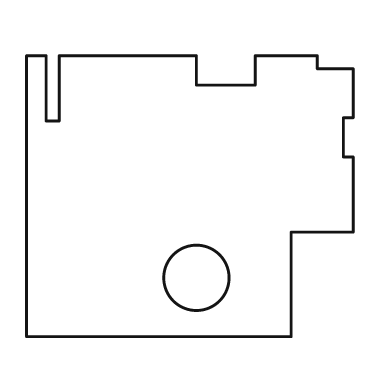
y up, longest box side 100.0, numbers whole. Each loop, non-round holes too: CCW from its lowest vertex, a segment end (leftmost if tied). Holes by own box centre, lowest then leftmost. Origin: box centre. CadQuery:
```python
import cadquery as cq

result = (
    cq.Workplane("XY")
    .moveTo(-50.0, -43.0)
    .lineTo(31.0, -43.0)
    .lineTo(31.0, -11.0)
    .lineTo(50.0, -11.0)
    .lineTo(50.0, 12.0)
    .lineTo(47.0, 12.0)
    .lineTo(47.0, 24.0)
    .lineTo(50.0, 24.0)
    .lineTo(50.0, 39.0)
    .lineTo(39.0, 39.0)
    .lineTo(39.0, 43.0)
    .lineTo(20.0, 43.0)
    .lineTo(20.0, 34.0)
    .lineTo(2.0, 34.0)
    .lineTo(2.0, 43.0)
    .lineTo(-40.0, 43.0)
    .lineTo(-40.0, 23.0)
    .lineTo(-44.0, 23.0)
    .lineTo(-44.0, 43.0)
    .lineTo(-50.0, 43.0)
    .close()
    .moveTo(2.0, -25.0)
    .circle(10.0)
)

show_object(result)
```